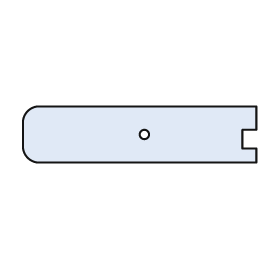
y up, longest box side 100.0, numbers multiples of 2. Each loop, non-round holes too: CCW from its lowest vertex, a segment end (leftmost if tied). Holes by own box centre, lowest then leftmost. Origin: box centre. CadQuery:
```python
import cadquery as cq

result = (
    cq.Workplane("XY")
    .moveTo(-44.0, -12.0)
    .lineTo(50.0, -12.0)
    .lineTo(50.0, -6.0)
    .lineTo(44.0, -6.0)
    .lineTo(44.0, 2.0)
    .lineTo(50.0, 2.0)
    .lineTo(50.0, 12.0)
    .lineTo(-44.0, 12.0)
    .threePointArc((-48.0, 10.0), (-50.0, 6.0))
    .lineTo(-50.0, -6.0)
    .threePointArc((-48.0, -10.0), (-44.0, -12.0))
    .close()
    .moveTo(2.0, 0.0)
    .circle(2.0)
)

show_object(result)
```